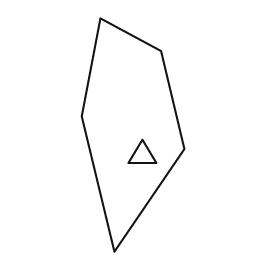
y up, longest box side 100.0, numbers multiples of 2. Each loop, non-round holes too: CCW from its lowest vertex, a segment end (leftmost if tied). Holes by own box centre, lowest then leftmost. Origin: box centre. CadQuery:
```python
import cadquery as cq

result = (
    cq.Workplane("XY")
    .moveTo(-8.0, -50.0)
    .lineTo(22.0, -6.0)
    .lineTo(12.0, 36.0)
    .lineTo(-14.0, 50.0)
    .lineTo(-22.0, 8.0)
    .close()
    .moveTo(-2.0, -12.0)
    .lineTo(10.0, -12.0)
    .lineTo(4.0, -2.0)
    .close()
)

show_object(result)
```